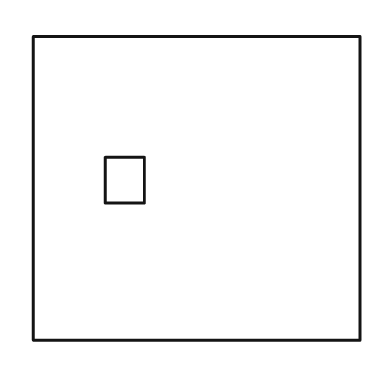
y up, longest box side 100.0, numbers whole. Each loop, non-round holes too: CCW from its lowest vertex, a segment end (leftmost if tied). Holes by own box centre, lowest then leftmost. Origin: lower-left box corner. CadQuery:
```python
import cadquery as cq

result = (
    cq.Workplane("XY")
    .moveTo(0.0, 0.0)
    .lineTo(100.0, 0.0)
    .lineTo(100.0, 93.0)
    .lineTo(0.0, 93.0)
    .close()
    .moveTo(22.0, 42.0)
    .lineTo(34.0, 42.0)
    .lineTo(34.0, 56.0)
    .lineTo(22.0, 56.0)
    .close()
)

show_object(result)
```